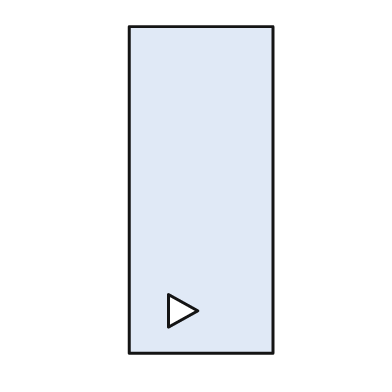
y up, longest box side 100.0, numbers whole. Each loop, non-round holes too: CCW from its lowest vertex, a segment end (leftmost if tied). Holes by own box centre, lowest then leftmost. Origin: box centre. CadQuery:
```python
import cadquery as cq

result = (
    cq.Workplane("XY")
    .moveTo(-22.0, -50.0)
    .lineTo(22.0, -50.0)
    .lineTo(22.0, 50.0)
    .lineTo(-22.0, 50.0)
    .close()
    .moveTo(-10.0, -42.0)
    .lineTo(-1.0, -37.0)
    .lineTo(-10.0, -32.0)
    .close()
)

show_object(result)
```